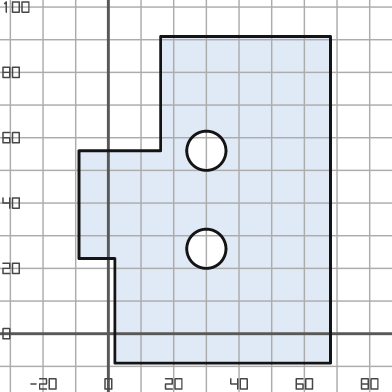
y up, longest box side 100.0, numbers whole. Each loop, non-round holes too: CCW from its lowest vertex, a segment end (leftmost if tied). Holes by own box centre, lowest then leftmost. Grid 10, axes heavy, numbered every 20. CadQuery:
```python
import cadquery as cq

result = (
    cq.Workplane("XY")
    .moveTo(2.0, -9.0)
    .lineTo(68.0, -9.0)
    .lineTo(68.0, 91.0)
    .lineTo(16.0, 91.0)
    .lineTo(16.0, 56.0)
    .lineTo(-9.0, 56.0)
    .lineTo(-9.0, 23.0)
    .lineTo(2.0, 23.0)
    .close()
    .moveTo(30.0, 26.0)
    .circle(6.0)
    .moveTo(30.0, 56.0)
    .circle(6.0)
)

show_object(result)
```